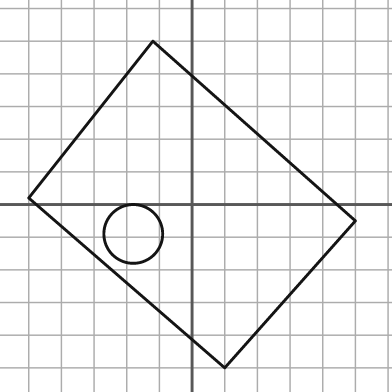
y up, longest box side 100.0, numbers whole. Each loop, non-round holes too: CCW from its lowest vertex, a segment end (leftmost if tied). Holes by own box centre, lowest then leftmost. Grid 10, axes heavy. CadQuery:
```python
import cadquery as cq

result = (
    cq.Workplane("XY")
    .moveTo(10.0, -50.0)
    .lineTo(50.0, -5.0)
    .lineTo(-12.0, 50.0)
    .lineTo(-50.0, 2.0)
    .close()
    .moveTo(-18.0, -9.0)
    .circle(9.0)
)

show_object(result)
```